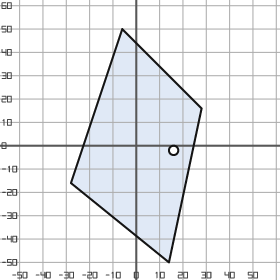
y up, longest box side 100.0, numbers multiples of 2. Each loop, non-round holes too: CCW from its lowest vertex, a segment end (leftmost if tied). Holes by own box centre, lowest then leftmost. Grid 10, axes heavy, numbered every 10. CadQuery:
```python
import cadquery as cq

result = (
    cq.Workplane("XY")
    .moveTo(14.0, -50.0)
    .lineTo(28.0, 16.0)
    .lineTo(-6.0, 50.0)
    .lineTo(-28.0, -16.0)
    .close()
    .moveTo(16.0, -2.0)
    .circle(2.0)
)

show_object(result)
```